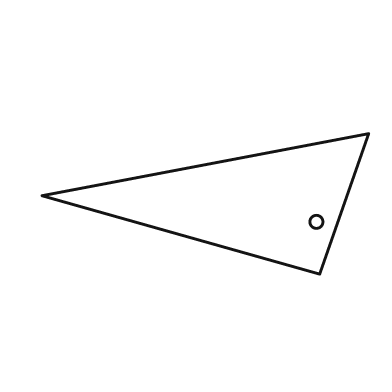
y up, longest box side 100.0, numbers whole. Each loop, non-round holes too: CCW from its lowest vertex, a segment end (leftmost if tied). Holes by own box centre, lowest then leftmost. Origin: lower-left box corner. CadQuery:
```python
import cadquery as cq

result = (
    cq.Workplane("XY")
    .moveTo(85.0, 0.0)
    .lineTo(100.0, 43.0)
    .lineTo(0.0, 24.0)
    .close()
    .moveTo(84.0, 16.0)
    .circle(2.0)
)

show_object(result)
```